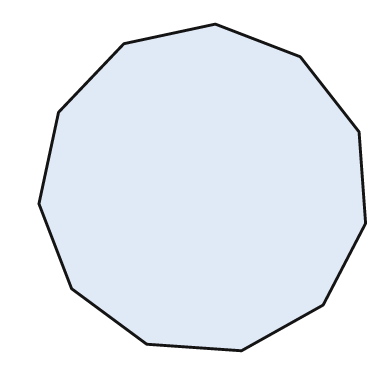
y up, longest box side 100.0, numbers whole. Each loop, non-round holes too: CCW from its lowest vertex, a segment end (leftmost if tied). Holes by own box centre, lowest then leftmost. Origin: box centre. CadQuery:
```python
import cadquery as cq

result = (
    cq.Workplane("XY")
    .moveTo(12.0, -50.0)
    .lineTo(37.0, -36.0)
    .lineTo(50.0, -11.0)
    .lineTo(48.0, 17.0)
    .lineTo(30.0, 40.0)
    .lineTo(4.0, 50.0)
    .lineTo(-24.0, 44.0)
    .lineTo(-44.0, 23.0)
    .lineTo(-50.0, -5.0)
    .lineTo(-40.0, -31.0)
    .lineTo(-17.0, -48.0)
    .close()
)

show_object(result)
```